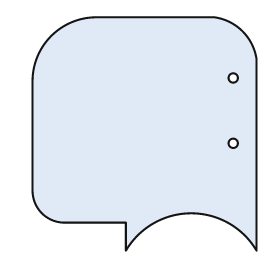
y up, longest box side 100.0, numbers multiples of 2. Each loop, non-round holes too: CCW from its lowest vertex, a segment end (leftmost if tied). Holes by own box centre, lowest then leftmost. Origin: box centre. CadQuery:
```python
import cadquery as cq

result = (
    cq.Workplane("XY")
    .moveTo(-8.0, -50.0)
    .threePointArc((20.0, -34.0), (48.0, -50.0))
    .lineTo(48.0, 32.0)
    .threePointArc((42.0, 44.0), (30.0, 50.0))
    .lineTo(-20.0, 50.0)
    .threePointArc((-40.0, 42.0), (-48.0, 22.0))
    .lineTo(-48.0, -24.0)
    .threePointArc((-44.0, -34.0), (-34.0, -38.0))
    .lineTo(-8.0, -38.0)
    .close()
    .moveTo(38.0, -4.0)
    .circle(2.0)
    .moveTo(38.0, 24.0)
    .circle(2.0)
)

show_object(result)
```